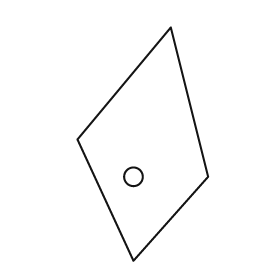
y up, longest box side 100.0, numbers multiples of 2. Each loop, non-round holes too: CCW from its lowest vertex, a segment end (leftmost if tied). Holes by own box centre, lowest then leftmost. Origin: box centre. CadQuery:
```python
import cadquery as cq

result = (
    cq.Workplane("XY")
    .moveTo(-4.0, -50.0)
    .lineTo(28.0, -14.0)
    .lineTo(12.0, 50.0)
    .lineTo(-28.0, 2.0)
    .close()
    .moveTo(-4.0, -14.0)
    .circle(4.0)
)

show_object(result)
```